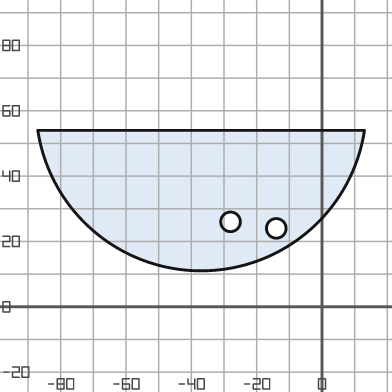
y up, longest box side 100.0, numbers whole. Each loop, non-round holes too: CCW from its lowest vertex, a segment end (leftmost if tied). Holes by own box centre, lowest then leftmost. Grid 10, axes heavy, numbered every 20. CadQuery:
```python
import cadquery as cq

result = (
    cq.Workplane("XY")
    .moveTo(-87.0, 54.0)
    .threePointArc((-37.0, 11.0), (13.0, 54.0))
    .close()
    .moveTo(-14.0, 24.0)
    .circle(3.0)
    .moveTo(-28.0, 26.0)
    .circle(3.0)
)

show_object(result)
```